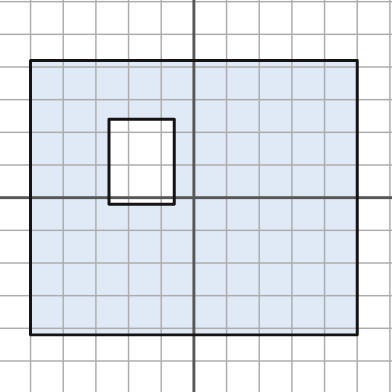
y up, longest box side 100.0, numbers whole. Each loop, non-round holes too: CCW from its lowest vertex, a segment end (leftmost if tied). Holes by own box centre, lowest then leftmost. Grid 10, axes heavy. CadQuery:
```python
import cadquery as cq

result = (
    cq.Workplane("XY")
    .moveTo(-50.0, -42.0)
    .lineTo(50.0, -42.0)
    .lineTo(50.0, 42.0)
    .lineTo(-50.0, 42.0)
    .close()
    .moveTo(-26.0, -2.0)
    .lineTo(-6.0, -2.0)
    .lineTo(-6.0, 24.0)
    .lineTo(-26.0, 24.0)
    .close()
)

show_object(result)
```